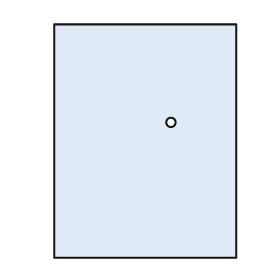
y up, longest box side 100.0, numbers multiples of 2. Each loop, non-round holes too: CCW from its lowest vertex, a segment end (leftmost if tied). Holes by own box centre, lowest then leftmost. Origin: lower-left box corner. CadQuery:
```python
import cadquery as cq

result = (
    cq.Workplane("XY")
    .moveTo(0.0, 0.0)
    .lineTo(78.0, 0.0)
    .lineTo(78.0, 100.0)
    .lineTo(0.0, 100.0)
    .close()
    .moveTo(50.0, 58.0)
    .circle(2.0)
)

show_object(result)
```